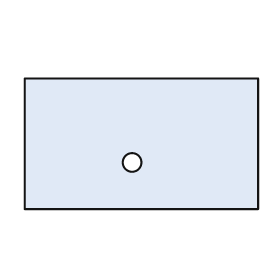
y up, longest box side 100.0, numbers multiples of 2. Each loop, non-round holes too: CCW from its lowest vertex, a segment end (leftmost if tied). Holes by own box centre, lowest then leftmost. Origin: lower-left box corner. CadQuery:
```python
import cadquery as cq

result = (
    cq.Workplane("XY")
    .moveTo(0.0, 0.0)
    .lineTo(100.0, 0.0)
    .lineTo(100.0, 56.0)
    .lineTo(0.0, 56.0)
    .close()
    .moveTo(46.0, 20.0)
    .circle(4.0)
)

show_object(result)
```